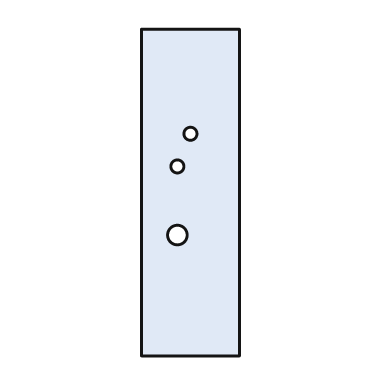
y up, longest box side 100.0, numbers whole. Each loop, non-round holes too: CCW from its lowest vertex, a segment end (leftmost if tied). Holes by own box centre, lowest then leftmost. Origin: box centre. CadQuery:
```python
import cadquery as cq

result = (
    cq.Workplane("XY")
    .moveTo(-15.0, -50.0)
    .lineTo(15.0, -50.0)
    .lineTo(15.0, 50.0)
    .lineTo(-15.0, 50.0)
    .close()
    .moveTo(-4.0, -13.0)
    .circle(3.0)
    .moveTo(-4.0, 8.0)
    .circle(2.0)
    .moveTo(0.0, 18.0)
    .circle(2.0)
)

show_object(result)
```